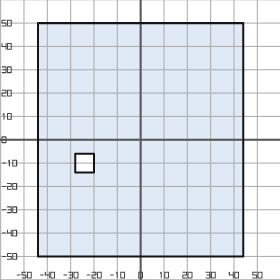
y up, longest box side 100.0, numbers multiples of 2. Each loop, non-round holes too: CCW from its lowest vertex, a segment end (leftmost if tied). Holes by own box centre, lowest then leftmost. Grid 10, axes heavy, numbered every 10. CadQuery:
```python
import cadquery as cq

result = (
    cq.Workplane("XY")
    .moveTo(-44.0, -50.0)
    .lineTo(44.0, -50.0)
    .lineTo(44.0, 50.0)
    .lineTo(-44.0, 50.0)
    .close()
    .moveTo(-28.0, -14.0)
    .lineTo(-20.0, -14.0)
    .lineTo(-20.0, -6.0)
    .lineTo(-28.0, -6.0)
    .close()
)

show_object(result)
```